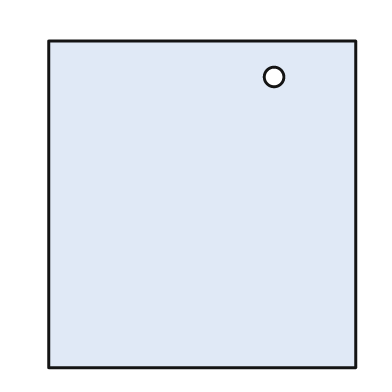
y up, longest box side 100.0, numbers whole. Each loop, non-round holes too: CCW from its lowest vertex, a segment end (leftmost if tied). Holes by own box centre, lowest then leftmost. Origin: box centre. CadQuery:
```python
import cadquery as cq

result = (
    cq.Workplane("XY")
    .moveTo(-47.0, -50.0)
    .lineTo(47.0, -50.0)
    .lineTo(47.0, 50.0)
    .lineTo(-47.0, 50.0)
    .close()
    .moveTo(22.0, 39.0)
    .circle(3.0)
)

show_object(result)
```